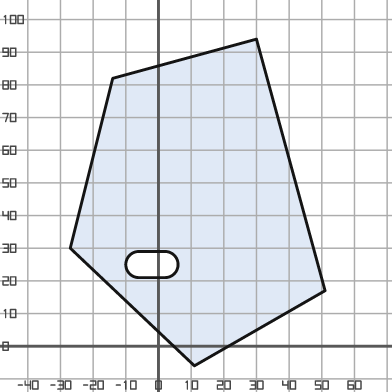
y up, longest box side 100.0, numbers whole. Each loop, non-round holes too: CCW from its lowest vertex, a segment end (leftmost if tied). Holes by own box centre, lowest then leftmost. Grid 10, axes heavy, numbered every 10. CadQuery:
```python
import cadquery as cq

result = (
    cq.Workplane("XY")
    .moveTo(11.0, -6.0)
    .lineTo(51.0, 17.0)
    .lineTo(30.0, 94.0)
    .lineTo(-14.0, 82.0)
    .lineTo(-27.0, 30.0)
    .close()
    .moveTo(-6.0, 21.0)
    .lineTo(2.0, 21.0)
    .threePointArc((6.0, 25.0), (2.0, 29.0))
    .lineTo(-6.0, 29.0)
    .threePointArc((-10.0, 25.0), (-6.0, 21.0))
    .close()
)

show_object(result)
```